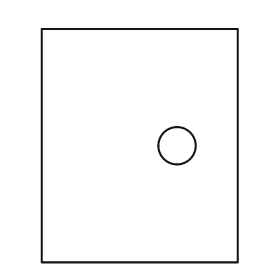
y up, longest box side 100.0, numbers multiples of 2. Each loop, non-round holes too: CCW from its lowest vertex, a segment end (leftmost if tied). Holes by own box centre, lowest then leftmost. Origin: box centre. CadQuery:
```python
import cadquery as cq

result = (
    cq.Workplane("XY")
    .moveTo(-42.0, -50.0)
    .lineTo(42.0, -50.0)
    .lineTo(42.0, 50.0)
    .lineTo(-42.0, 50.0)
    .close()
    .moveTo(16.0, 0.0)
    .circle(8.0)
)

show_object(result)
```